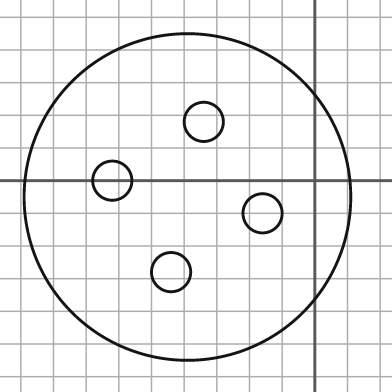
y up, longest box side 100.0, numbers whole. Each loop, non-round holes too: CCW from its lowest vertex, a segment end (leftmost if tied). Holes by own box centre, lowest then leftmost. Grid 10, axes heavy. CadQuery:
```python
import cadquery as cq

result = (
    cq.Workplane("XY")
    .moveTo(-39.0, -5.0)
    .circle(50.0)
    .moveTo(-44.0, -28.0)
    .circle(6.0)
    .moveTo(-16.0, -10.0)
    .circle(6.0)
    .moveTo(-62.0, 0.0)
    .circle(6.0)
    .moveTo(-34.0, 18.0)
    .circle(6.0)
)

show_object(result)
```